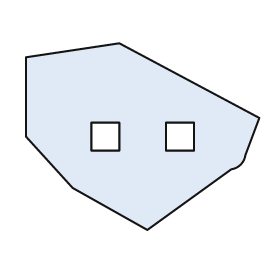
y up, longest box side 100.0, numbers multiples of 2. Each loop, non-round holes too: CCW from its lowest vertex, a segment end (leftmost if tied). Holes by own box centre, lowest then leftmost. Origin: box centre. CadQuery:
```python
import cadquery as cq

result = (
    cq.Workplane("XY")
    .moveTo(2.0, -40.0)
    .lineTo(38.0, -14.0)
    .threePointArc((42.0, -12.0), (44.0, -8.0))
    .lineTo(50.0, 8.0)
    .lineTo(-10.0, 40.0)
    .lineTo(-50.0, 34.0)
    .lineTo(-50.0, 0.0)
    .lineTo(-30.0, -22.0)
    .close()
    .moveTo(-22.0, -6.0)
    .lineTo(-10.0, -6.0)
    .lineTo(-10.0, 6.0)
    .lineTo(-22.0, 6.0)
    .close()
    .moveTo(10.0, -6.0)
    .lineTo(22.0, -6.0)
    .lineTo(22.0, 6.0)
    .lineTo(10.0, 6.0)
    .close()
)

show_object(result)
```